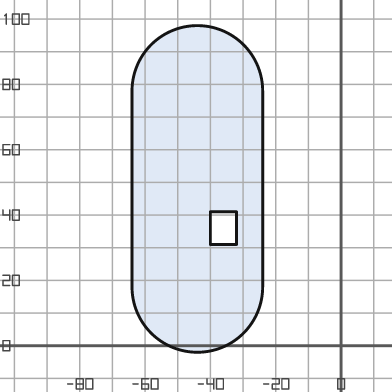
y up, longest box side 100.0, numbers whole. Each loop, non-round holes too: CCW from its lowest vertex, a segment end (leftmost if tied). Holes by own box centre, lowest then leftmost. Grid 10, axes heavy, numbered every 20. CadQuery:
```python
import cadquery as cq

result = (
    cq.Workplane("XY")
    .moveTo(-64.0, 18.0)
    .threePointArc((-44.0, -2.0), (-24.0, 18.0))
    .lineTo(-24.0, 78.0)
    .threePointArc((-44.0, 98.0), (-64.0, 78.0))
    .close()
    .moveTo(-40.0, 31.0)
    .lineTo(-32.0, 31.0)
    .lineTo(-32.0, 41.0)
    .lineTo(-40.0, 41.0)
    .close()
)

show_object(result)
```